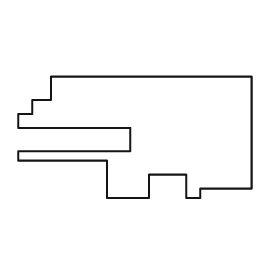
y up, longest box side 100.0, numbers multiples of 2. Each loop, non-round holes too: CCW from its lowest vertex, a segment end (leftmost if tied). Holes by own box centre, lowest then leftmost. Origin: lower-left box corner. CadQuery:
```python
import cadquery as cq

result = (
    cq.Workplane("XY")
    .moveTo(38.0, 0.0)
    .lineTo(56.0, 0.0)
    .lineTo(56.0, 10.0)
    .lineTo(72.0, 10.0)
    .lineTo(72.0, 0.0)
    .lineTo(78.0, 0.0)
    .lineTo(78.0, 4.0)
    .lineTo(100.0, 4.0)
    .lineTo(100.0, 52.0)
    .lineTo(14.0, 52.0)
    .lineTo(14.0, 42.0)
    .lineTo(6.0, 42.0)
    .lineTo(6.0, 36.0)
    .lineTo(0.0, 36.0)
    .lineTo(0.0, 30.0)
    .lineTo(48.0, 30.0)
    .lineTo(48.0, 20.0)
    .lineTo(0.0, 20.0)
    .lineTo(0.0, 16.0)
    .lineTo(38.0, 16.0)
    .close()
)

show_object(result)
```